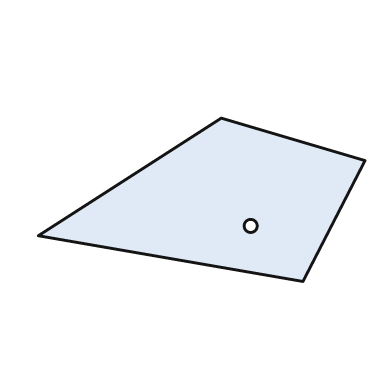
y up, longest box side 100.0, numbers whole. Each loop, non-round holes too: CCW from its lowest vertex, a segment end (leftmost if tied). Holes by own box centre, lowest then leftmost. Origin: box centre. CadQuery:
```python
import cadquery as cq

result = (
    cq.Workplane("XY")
    .moveTo(31.0, -25.0)
    .lineTo(50.0, 12.0)
    .lineTo(6.0, 25.0)
    .lineTo(-50.0, -11.0)
    .close()
    .moveTo(15.0, -8.0)
    .circle(2.0)
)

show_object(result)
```